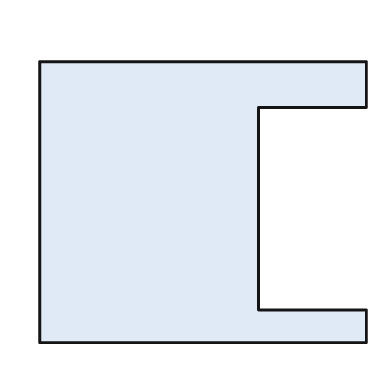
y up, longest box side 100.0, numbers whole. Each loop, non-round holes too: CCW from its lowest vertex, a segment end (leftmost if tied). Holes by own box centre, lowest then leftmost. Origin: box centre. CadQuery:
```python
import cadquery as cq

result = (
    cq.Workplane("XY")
    .moveTo(-50.0, -43.0)
    .lineTo(50.0, -43.0)
    .lineTo(50.0, -33.0)
    .lineTo(17.0, -33.0)
    .lineTo(17.0, 29.0)
    .lineTo(50.0, 29.0)
    .lineTo(50.0, 43.0)
    .lineTo(-50.0, 43.0)
    .close()
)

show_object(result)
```